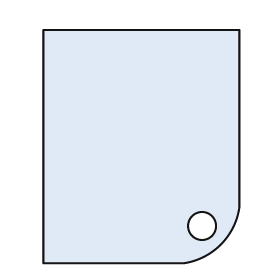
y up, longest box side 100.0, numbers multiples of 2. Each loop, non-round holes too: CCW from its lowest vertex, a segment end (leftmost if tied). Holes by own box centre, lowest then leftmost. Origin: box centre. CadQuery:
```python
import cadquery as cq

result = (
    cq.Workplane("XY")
    .moveTo(-42.0, -50.0)
    .lineTo(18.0, -50.0)
    .threePointArc((34.0, -42.0), (42.0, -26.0))
    .lineTo(42.0, 50.0)
    .lineTo(-42.0, 50.0)
    .close()
    .moveTo(26.0, -34.0)
    .circle(6.0)
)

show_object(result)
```